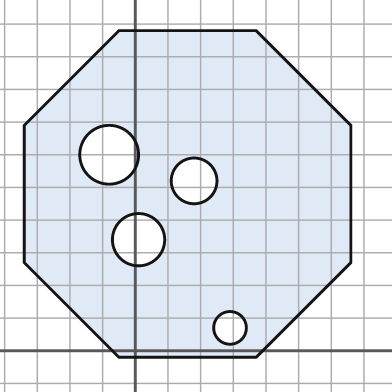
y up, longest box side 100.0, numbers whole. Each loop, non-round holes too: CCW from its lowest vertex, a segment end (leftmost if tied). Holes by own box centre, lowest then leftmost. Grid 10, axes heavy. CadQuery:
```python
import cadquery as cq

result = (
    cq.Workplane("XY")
    .moveTo(-5.0, -2.0)
    .lineTo(37.0, -2.0)
    .lineTo(66.0, 27.0)
    .lineTo(66.0, 69.0)
    .lineTo(37.0, 98.0)
    .lineTo(-5.0, 98.0)
    .lineTo(-34.0, 69.0)
    .lineTo(-34.0, 27.0)
    .close()
    .moveTo(29.0, 7.0)
    .circle(5.0)
    .moveTo(1.0, 34.0)
    .circle(8.0)
    .moveTo(18.0, 52.0)
    .circle(7.0)
    .moveTo(-8.0, 60.0)
    .circle(9.0)
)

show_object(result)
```